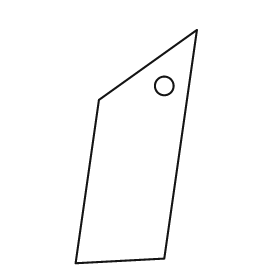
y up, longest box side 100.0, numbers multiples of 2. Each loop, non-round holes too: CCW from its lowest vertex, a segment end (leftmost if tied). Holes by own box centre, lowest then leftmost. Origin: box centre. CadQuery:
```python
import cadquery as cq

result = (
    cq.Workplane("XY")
    .moveTo(-26.0, -50.0)
    .lineTo(12.0, -48.0)
    .lineTo(26.0, 50.0)
    .lineTo(-16.0, 20.0)
    .close()
    .moveTo(12.0, 26.0)
    .circle(4.0)
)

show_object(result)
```